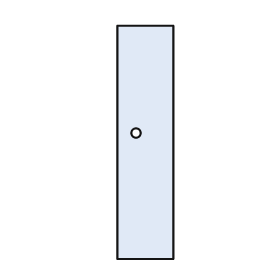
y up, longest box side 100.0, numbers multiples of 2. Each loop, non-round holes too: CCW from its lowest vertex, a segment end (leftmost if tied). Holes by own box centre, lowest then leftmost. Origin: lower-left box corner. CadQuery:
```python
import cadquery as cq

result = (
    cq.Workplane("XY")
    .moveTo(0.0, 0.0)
    .lineTo(24.0, 0.0)
    .lineTo(24.0, 100.0)
    .lineTo(0.0, 100.0)
    .close()
    .moveTo(8.0, 54.0)
    .circle(2.0)
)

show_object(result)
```